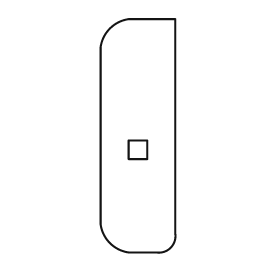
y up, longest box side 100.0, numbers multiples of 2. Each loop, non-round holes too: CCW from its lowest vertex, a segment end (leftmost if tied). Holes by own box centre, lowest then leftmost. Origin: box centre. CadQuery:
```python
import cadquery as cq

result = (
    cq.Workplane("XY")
    .moveTo(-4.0, -50.0)
    .lineTo(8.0, -50.0)
    .threePointArc((14.0, -48.0), (16.0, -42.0))
    .lineTo(16.0, 50.0)
    .lineTo(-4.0, 50.0)
    .threePointArc((-12.0, 46.0), (-16.0, 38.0))
    .lineTo(-16.0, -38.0)
    .threePointArc((-12.0, -46.0), (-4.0, -50.0))
    .close()
    .moveTo(-4.0, -10.0)
    .lineTo(4.0, -10.0)
    .lineTo(4.0, -2.0)
    .lineTo(-4.0, -2.0)
    .close()
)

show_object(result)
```